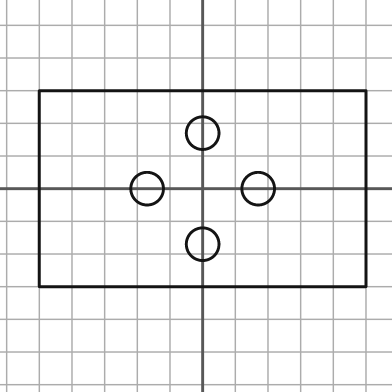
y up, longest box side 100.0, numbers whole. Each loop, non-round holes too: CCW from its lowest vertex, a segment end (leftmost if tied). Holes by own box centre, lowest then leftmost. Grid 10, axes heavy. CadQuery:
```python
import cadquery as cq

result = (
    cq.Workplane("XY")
    .moveTo(-50.0, -30.0)
    .lineTo(50.0, -30.0)
    .lineTo(50.0, 30.0)
    .lineTo(-50.0, 30.0)
    .close()
    .moveTo(0.0, -17.0)
    .circle(5.0)
    .moveTo(-17.0, 0.0)
    .circle(5.0)
    .moveTo(17.0, 0.0)
    .circle(5.0)
    .moveTo(0.0, 17.0)
    .circle(5.0)
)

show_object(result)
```